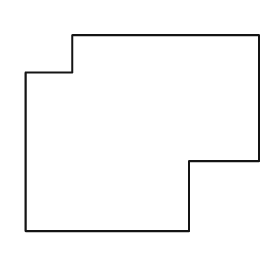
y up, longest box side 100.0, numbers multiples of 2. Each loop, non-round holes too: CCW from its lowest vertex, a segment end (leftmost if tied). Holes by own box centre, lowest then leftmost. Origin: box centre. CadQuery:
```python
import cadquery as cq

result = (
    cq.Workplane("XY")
    .moveTo(-50.0, -42.0)
    .lineTo(20.0, -42.0)
    .lineTo(20.0, -12.0)
    .lineTo(50.0, -12.0)
    .lineTo(50.0, 42.0)
    .lineTo(-30.0, 42.0)
    .lineTo(-30.0, 26.0)
    .lineTo(-50.0, 26.0)
    .close()
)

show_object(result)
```